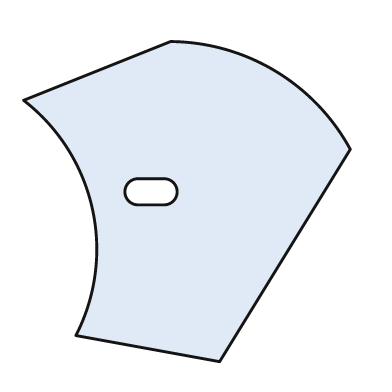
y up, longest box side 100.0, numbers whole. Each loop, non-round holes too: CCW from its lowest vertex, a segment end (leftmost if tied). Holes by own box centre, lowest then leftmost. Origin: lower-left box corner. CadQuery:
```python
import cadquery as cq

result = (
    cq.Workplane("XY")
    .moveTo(60.0, 0.0)
    .lineTo(100.0, 65.0)
    .threePointArc((77.0, 89.0), (45.0, 98.0))
    .lineTo(0.0, 80.0)
    .threePointArc((21.0, 47.0), (16.0, 8.0))
    .close()
    .moveTo(35.0, 48.0)
    .lineTo(43.0, 48.0)
    .threePointArc((47.0, 52.0), (43.0, 56.0))
    .lineTo(35.0, 56.0)
    .threePointArc((31.0, 52.0), (35.0, 48.0))
    .close()
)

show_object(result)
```